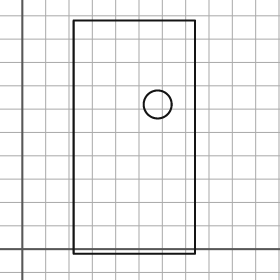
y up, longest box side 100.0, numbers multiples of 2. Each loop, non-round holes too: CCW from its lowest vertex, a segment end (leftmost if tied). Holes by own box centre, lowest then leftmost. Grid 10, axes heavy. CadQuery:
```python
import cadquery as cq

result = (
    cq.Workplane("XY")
    .moveTo(22.0, -2.0)
    .lineTo(74.0, -2.0)
    .lineTo(74.0, 98.0)
    .lineTo(22.0, 98.0)
    .close()
    .moveTo(58.0, 62.0)
    .circle(6.0)
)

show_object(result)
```